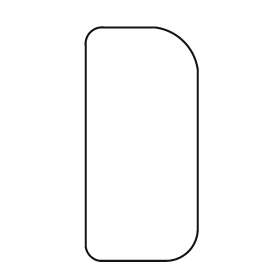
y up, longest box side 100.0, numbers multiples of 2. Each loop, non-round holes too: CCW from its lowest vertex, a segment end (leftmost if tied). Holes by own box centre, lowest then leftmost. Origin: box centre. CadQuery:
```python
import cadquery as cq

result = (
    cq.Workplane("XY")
    .moveTo(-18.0, -50.0)
    .lineTo(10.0, -50.0)
    .threePointArc((20.0, -46.0), (24.0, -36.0))
    .lineTo(24.0, 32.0)
    .threePointArc((18.0, 44.0), (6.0, 50.0))
    .lineTo(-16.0, 50.0)
    .threePointArc((-22.0, 48.0), (-24.0, 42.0))
    .lineTo(-24.0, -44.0)
    .threePointArc((-22.0, -48.0), (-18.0, -50.0))
    .close()
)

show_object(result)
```